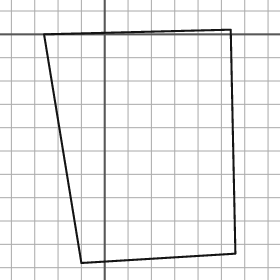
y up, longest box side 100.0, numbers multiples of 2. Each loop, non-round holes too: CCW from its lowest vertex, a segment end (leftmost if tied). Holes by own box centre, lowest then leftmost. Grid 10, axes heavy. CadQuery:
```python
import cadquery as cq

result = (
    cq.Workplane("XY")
    .moveTo(-10.0, -98.0)
    .lineTo(56.0, -94.0)
    .lineTo(54.0, 2.0)
    .lineTo(-26.0, 0.0)
    .close()
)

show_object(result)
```